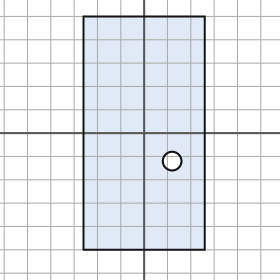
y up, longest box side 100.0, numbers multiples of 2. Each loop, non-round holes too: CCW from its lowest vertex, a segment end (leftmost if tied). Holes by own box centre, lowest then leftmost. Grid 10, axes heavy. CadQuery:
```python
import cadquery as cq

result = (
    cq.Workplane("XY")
    .moveTo(-26.0, -50.0)
    .lineTo(26.0, -50.0)
    .lineTo(26.0, 50.0)
    .lineTo(-26.0, 50.0)
    .close()
    .moveTo(12.0, -12.0)
    .circle(4.0)
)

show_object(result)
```